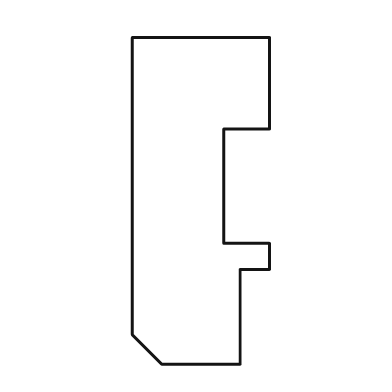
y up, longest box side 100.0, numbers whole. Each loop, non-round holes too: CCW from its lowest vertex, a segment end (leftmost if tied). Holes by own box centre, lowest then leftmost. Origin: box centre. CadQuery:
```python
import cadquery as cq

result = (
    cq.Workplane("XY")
    .moveTo(-12.0, -50.0)
    .lineTo(12.0, -50.0)
    .lineTo(12.0, -21.0)
    .lineTo(21.0, -21.0)
    .lineTo(21.0, -13.0)
    .lineTo(7.0, -13.0)
    .lineTo(7.0, 22.0)
    .lineTo(21.0, 22.0)
    .lineTo(21.0, 50.0)
    .lineTo(-21.0, 50.0)
    .lineTo(-21.0, -41.0)
    .close()
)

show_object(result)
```